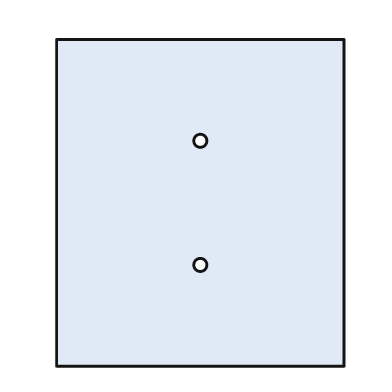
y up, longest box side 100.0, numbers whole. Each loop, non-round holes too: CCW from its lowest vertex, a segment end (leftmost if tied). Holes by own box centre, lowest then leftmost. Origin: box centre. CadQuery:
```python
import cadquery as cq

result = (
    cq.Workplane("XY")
    .moveTo(-44.0, -50.0)
    .lineTo(44.0, -50.0)
    .lineTo(44.0, 50.0)
    .lineTo(-44.0, 50.0)
    .close()
    .moveTo(0.0, -19.0)
    .circle(2.0)
    .moveTo(0.0, 19.0)
    .circle(2.0)
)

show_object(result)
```